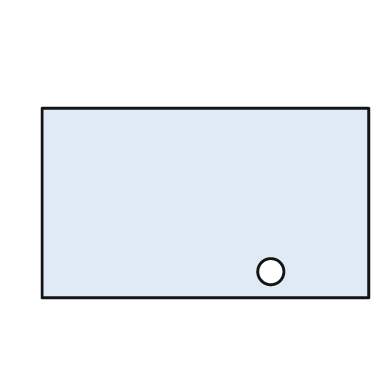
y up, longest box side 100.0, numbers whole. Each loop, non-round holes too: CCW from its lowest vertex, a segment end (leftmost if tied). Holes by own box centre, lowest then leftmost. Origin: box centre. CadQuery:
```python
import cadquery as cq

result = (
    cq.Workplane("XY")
    .moveTo(-50.0, -29.0)
    .lineTo(50.0, -29.0)
    .lineTo(50.0, 29.0)
    .lineTo(-50.0, 29.0)
    .close()
    .moveTo(20.0, -21.0)
    .circle(4.0)
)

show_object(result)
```